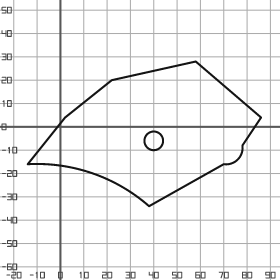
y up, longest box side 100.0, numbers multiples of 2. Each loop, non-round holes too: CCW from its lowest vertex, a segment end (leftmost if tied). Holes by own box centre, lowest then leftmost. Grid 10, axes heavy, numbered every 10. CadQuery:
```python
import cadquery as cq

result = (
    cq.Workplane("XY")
    .moveTo(38.0, -34.0)
    .lineTo(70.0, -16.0)
    .threePointArc((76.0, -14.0), (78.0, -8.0))
    .lineTo(86.0, 4.0)
    .lineTo(58.0, 28.0)
    .lineTo(22.0, 20.0)
    .lineTo(2.0, 4.0)
    .lineTo(-14.0, -16.0)
    .threePointArc((14.0, -20.0), (38.0, -34.0))
    .close()
    .moveTo(40.0, -6.0)
    .circle(4.0)
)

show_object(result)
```